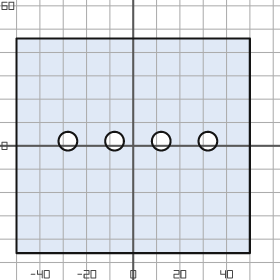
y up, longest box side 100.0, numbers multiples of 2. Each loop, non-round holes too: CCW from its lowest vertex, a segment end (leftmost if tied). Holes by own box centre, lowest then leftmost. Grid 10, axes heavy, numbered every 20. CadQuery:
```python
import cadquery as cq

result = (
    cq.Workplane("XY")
    .moveTo(-50.0, -46.0)
    .lineTo(50.0, -46.0)
    .lineTo(50.0, 46.0)
    .lineTo(-50.0, 46.0)
    .close()
    .moveTo(-28.0, 2.0)
    .circle(4.0)
    .moveTo(-8.0, 2.0)
    .circle(4.0)
    .moveTo(12.0, 2.0)
    .circle(4.0)
    .moveTo(32.0, 2.0)
    .circle(4.0)
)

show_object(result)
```